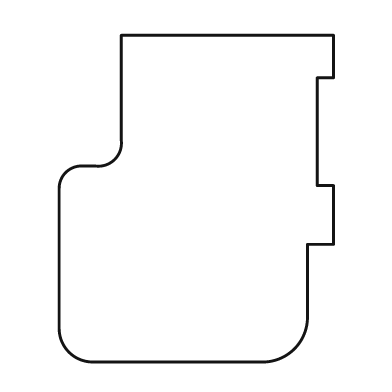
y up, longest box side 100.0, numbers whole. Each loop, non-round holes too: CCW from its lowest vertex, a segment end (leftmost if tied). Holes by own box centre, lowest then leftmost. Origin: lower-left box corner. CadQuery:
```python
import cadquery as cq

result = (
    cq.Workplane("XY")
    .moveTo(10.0, 0.0)
    .lineTo(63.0, 0.0)
    .threePointArc((72.0, 4.0), (76.0, 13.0))
    .lineTo(76.0, 36.0)
    .lineTo(84.0, 36.0)
    .lineTo(84.0, 54.0)
    .lineTo(79.0, 54.0)
    .lineTo(79.0, 87.0)
    .lineTo(84.0, 87.0)
    .lineTo(84.0, 100.0)
    .lineTo(19.0, 100.0)
    .lineTo(19.0, 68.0)
    .threePointArc((17.0, 62.0), (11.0, 60.0))
    .lineTo(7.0, 60.0)
    .threePointArc((2.0, 58.0), (0.0, 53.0))
    .lineTo(0.0, 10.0)
    .threePointArc((3.0, 3.0), (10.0, 0.0))
    .close()
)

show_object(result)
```